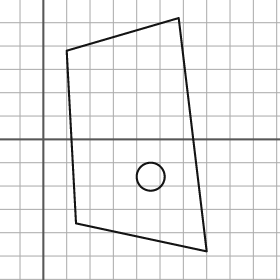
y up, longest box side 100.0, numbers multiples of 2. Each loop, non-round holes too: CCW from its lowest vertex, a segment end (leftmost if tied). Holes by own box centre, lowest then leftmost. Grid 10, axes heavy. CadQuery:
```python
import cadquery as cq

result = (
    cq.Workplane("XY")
    .moveTo(70.0, -48.0)
    .lineTo(58.0, 52.0)
    .lineTo(10.0, 38.0)
    .lineTo(14.0, -36.0)
    .close()
    .moveTo(46.0, -16.0)
    .circle(6.0)
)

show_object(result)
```